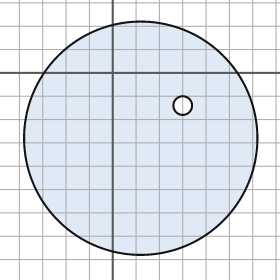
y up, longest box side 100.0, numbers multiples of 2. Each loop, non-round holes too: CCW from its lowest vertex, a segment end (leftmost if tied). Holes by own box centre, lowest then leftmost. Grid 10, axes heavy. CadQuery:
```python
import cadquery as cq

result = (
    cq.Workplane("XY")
    .moveTo(12.0, -28.0)
    .circle(50.0)
    .moveTo(30.0, -14.0)
    .circle(4.0)
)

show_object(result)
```